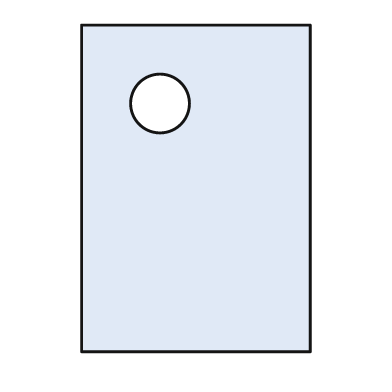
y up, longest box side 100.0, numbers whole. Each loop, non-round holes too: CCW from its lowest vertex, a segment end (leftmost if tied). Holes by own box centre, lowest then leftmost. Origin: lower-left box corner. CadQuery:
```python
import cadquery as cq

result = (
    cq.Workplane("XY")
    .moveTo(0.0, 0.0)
    .lineTo(70.0, 0.0)
    .lineTo(70.0, 100.0)
    .lineTo(0.0, 100.0)
    .close()
    .moveTo(24.0, 76.0)
    .circle(9.0)
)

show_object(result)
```